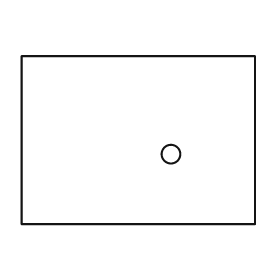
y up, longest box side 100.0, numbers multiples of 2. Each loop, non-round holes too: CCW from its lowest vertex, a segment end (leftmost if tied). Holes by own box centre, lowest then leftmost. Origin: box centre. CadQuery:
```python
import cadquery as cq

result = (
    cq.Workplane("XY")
    .moveTo(-50.0, -36.0)
    .lineTo(50.0, -36.0)
    .lineTo(50.0, 36.0)
    .lineTo(-50.0, 36.0)
    .close()
    .moveTo(14.0, -6.0)
    .circle(4.0)
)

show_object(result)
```